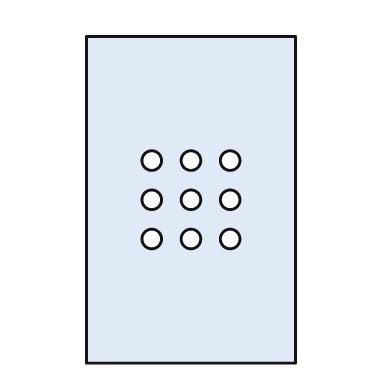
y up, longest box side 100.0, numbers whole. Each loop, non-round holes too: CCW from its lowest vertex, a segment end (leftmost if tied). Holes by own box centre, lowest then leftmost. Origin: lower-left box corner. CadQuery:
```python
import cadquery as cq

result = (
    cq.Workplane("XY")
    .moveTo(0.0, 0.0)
    .lineTo(64.0, 0.0)
    .lineTo(64.0, 100.0)
    .lineTo(0.0, 100.0)
    .close()
    .moveTo(20.0, 38.0)
    .circle(3.0)
    .moveTo(32.0, 38.0)
    .circle(3.0)
    .moveTo(44.0, 38.0)
    .circle(3.0)
    .moveTo(20.0, 50.0)
    .circle(3.0)
    .moveTo(32.0, 50.0)
    .circle(3.0)
    .moveTo(44.0, 50.0)
    .circle(3.0)
    .moveTo(20.0, 62.0)
    .circle(3.0)
    .moveTo(32.0, 62.0)
    .circle(3.0)
    .moveTo(44.0, 62.0)
    .circle(3.0)
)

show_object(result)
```